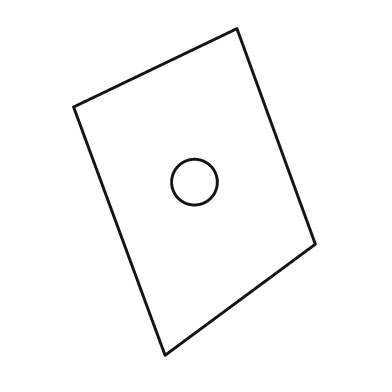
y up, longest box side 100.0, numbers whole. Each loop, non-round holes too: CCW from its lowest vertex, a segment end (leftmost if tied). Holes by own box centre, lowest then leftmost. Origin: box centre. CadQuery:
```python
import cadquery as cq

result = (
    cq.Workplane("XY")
    .moveTo(-9.0, -50.0)
    .lineTo(37.0, -16.0)
    .lineTo(13.0, 50.0)
    .lineTo(-37.0, 26.0)
    .close()
    .moveTo(0.0, 3.0)
    .circle(7.0)
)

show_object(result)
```